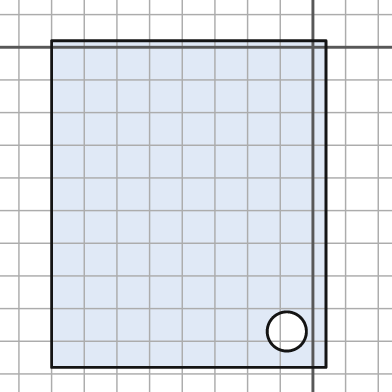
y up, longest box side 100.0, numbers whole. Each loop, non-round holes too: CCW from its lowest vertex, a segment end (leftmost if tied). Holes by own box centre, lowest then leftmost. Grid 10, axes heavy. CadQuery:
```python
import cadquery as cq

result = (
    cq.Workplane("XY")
    .moveTo(-80.0, -98.0)
    .lineTo(4.0, -98.0)
    .lineTo(4.0, 2.0)
    .lineTo(-80.0, 2.0)
    .close()
    .moveTo(-8.0, -87.0)
    .circle(6.0)
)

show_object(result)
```